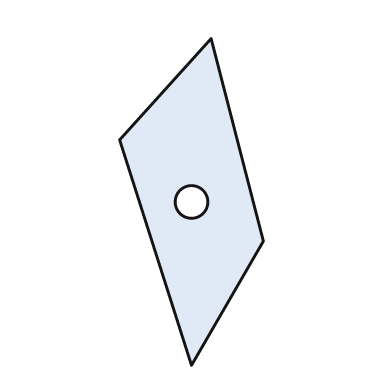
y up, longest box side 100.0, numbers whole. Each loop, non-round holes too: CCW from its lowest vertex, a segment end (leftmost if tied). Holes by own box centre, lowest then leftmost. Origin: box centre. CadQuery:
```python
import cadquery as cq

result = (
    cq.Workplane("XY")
    .moveTo(0.0, -50.0)
    .lineTo(22.0, -12.0)
    .lineTo(6.0, 50.0)
    .lineTo(-22.0, 19.0)
    .close()
    .moveTo(0.0, 0.0)
    .circle(5.0)
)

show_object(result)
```